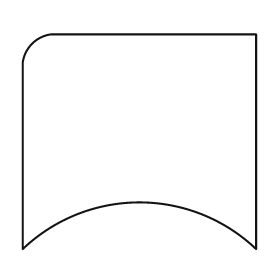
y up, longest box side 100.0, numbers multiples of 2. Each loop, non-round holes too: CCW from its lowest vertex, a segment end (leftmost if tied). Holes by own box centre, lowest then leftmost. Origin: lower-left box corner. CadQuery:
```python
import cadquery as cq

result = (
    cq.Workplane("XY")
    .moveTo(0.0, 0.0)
    .threePointArc((50.0, 20.0), (100.0, 0.0))
    .lineTo(100.0, 92.0)
    .lineTo(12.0, 92.0)
    .threePointArc((4.0, 88.0), (0.0, 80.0))
    .close()
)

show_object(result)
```